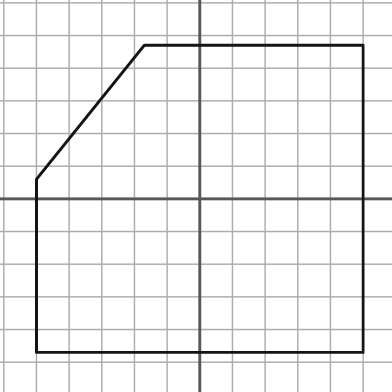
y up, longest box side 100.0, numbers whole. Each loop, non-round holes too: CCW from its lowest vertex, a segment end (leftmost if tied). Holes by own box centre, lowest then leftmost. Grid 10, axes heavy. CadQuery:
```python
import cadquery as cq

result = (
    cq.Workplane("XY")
    .moveTo(-50.0, -47.0)
    .lineTo(50.0, -47.0)
    .lineTo(50.0, 47.0)
    .lineTo(-17.0, 47.0)
    .lineTo(-50.0, 6.0)
    .close()
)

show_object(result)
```